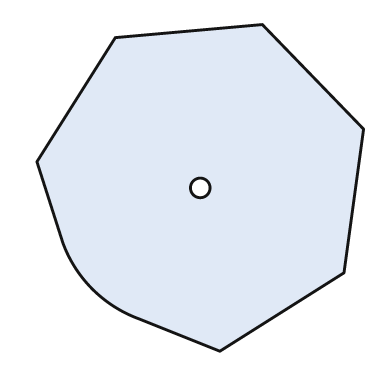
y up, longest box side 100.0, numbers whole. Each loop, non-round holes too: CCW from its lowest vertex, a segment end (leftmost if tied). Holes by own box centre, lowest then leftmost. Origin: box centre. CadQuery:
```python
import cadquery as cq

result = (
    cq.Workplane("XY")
    .moveTo(6.0, -50.0)
    .lineTo(44.0, -26.0)
    .lineTo(50.0, 18.0)
    .lineTo(19.0, 50.0)
    .lineTo(-26.0, 46.0)
    .lineTo(-50.0, 8.0)
    .lineTo(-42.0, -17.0)
    .threePointArc((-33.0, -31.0), (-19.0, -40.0))
    .close()
    .moveTo(0.0, 0.0)
    .circle(3.0)
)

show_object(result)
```